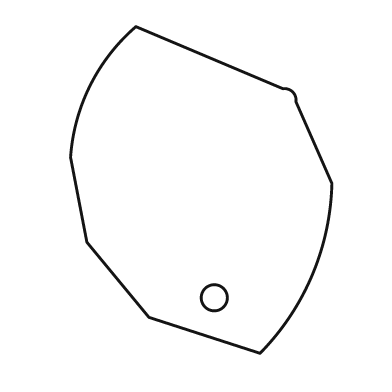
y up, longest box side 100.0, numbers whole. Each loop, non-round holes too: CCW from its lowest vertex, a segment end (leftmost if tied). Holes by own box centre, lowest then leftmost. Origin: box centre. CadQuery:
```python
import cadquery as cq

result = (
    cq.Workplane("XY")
    .moveTo(18.0, -50.0)
    .threePointArc((34.0, -26.0), (40.0, 2.0))
    .lineTo(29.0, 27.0)
    .threePointArc((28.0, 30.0), (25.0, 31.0))
    .lineTo(-20.0, 50.0)
    .threePointArc((-34.0, 32.0), (-40.0, 10.0))
    .lineTo(-35.0, -16.0)
    .lineTo(-16.0, -39.0)
    .close()
    .moveTo(4.0, -33.0)
    .circle(4.0)
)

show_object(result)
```